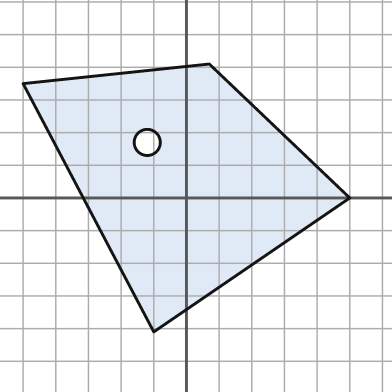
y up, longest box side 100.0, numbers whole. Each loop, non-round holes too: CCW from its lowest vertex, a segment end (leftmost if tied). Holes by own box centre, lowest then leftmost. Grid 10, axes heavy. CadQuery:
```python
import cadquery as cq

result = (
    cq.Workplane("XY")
    .moveTo(-10.0, -41.0)
    .lineTo(50.0, 0.0)
    .lineTo(7.0, 41.0)
    .lineTo(-50.0, 35.0)
    .close()
    .moveTo(-12.0, 17.0)
    .circle(4.0)
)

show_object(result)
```